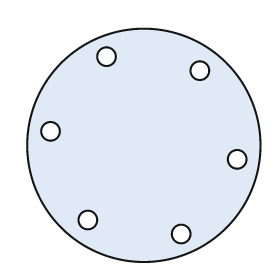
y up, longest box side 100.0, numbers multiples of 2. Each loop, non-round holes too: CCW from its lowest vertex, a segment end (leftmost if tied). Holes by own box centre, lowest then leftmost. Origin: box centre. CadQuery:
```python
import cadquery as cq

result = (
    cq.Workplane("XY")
    .moveTo(0.0, 0.0)
    .circle(50.0)
    .moveTo(16.0, -38.0)
    .circle(4.0)
    .moveTo(-24.0, -32.0)
    .circle(4.0)
    .moveTo(40.0, -6.0)
    .circle(4.0)
    .moveTo(-40.0, 6.0)
    .circle(4.0)
    .moveTo(24.0, 32.0)
    .circle(4.0)
    .moveTo(-16.0, 38.0)
    .circle(4.0)
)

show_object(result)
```